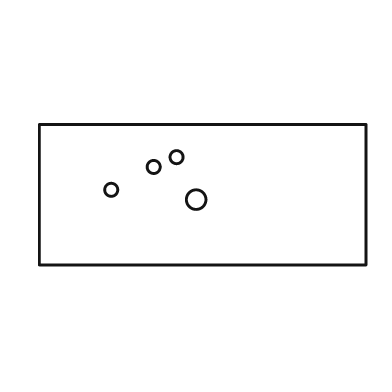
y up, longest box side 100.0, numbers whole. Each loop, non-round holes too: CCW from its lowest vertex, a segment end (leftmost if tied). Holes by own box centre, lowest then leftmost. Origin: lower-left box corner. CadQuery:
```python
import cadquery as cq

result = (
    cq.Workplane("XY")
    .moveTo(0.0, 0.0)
    .lineTo(100.0, 0.0)
    .lineTo(100.0, 43.0)
    .lineTo(0.0, 43.0)
    .close()
    .moveTo(48.0, 20.0)
    .circle(3.0)
    .moveTo(22.0, 23.0)
    .circle(2.0)
    .moveTo(35.0, 30.0)
    .circle(2.0)
    .moveTo(42.0, 33.0)
    .circle(2.0)
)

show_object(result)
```